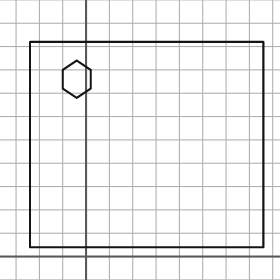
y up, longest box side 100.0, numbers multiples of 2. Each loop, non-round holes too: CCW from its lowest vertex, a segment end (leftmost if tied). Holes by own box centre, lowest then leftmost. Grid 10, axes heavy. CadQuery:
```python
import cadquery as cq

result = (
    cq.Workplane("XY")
    .moveTo(-24.0, 4.0)
    .lineTo(76.0, 4.0)
    .lineTo(76.0, 92.0)
    .lineTo(-24.0, 92.0)
    .close()
    .moveTo(-4.0, 68.0)
    .lineTo(2.0, 72.0)
    .lineTo(2.0, 80.0)
    .lineTo(-4.0, 84.0)
    .lineTo(-10.0, 80.0)
    .lineTo(-10.0, 72.0)
    .close()
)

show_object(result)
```